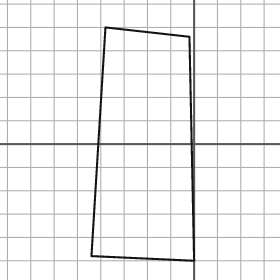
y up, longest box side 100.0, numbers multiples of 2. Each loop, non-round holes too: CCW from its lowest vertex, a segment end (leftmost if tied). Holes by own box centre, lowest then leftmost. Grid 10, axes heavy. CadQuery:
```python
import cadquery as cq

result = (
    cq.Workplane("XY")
    .moveTo(0.0, -50.0)
    .lineTo(-2.0, 46.0)
    .lineTo(-38.0, 50.0)
    .lineTo(-44.0, -48.0)
    .close()
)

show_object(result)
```